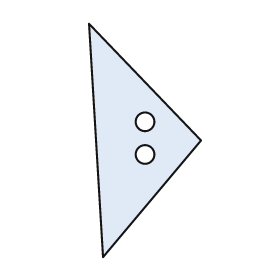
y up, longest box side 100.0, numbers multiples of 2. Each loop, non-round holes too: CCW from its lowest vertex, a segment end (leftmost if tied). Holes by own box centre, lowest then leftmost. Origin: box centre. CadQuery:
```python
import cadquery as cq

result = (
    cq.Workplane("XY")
    .moveTo(-18.0, -50.0)
    .lineTo(24.0, 0.0)
    .lineTo(-24.0, 50.0)
    .close()
    .moveTo(0.0, -6.0)
    .circle(4.0)
    .moveTo(0.0, 8.0)
    .circle(4.0)
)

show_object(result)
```